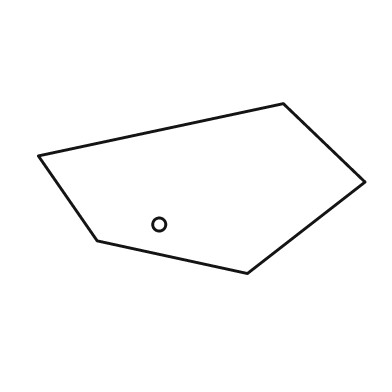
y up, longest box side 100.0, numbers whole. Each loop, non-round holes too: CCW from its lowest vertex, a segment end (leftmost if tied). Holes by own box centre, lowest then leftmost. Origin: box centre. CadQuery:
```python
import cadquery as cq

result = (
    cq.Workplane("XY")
    .moveTo(14.0, -26.0)
    .lineTo(50.0, 2.0)
    .lineTo(25.0, 26.0)
    .lineTo(-50.0, 10.0)
    .lineTo(-32.0, -16.0)
    .close()
    .moveTo(-13.0, -11.0)
    .circle(2.0)
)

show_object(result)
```